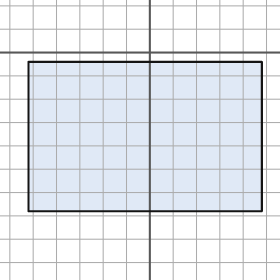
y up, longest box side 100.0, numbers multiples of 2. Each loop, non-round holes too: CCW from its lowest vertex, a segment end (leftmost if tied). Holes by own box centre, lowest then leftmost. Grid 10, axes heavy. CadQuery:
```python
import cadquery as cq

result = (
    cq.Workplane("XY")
    .moveTo(-52.0, -68.0)
    .lineTo(48.0, -68.0)
    .lineTo(48.0, -4.0)
    .lineTo(-52.0, -4.0)
    .close()
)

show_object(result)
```